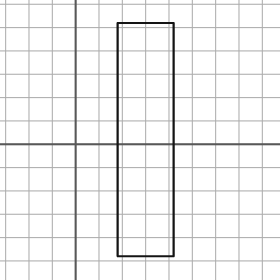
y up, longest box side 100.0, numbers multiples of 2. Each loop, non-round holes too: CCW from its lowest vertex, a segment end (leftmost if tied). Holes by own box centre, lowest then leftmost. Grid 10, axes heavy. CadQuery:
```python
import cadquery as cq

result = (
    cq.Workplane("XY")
    .moveTo(18.0, -48.0)
    .lineTo(42.0, -48.0)
    .lineTo(42.0, 52.0)
    .lineTo(18.0, 52.0)
    .close()
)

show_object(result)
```